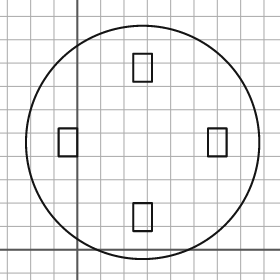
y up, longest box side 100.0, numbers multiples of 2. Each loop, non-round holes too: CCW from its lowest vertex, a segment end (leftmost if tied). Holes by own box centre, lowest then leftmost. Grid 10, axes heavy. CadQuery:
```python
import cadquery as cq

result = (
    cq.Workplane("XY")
    .moveTo(28.0, 46.0)
    .circle(50.0)
    .moveTo(24.0, 8.0)
    .lineTo(32.0, 8.0)
    .lineTo(32.0, 20.0)
    .lineTo(24.0, 20.0)
    .close()
    .moveTo(-8.0, 40.0)
    .lineTo(0.0, 40.0)
    .lineTo(0.0, 52.0)
    .lineTo(-8.0, 52.0)
    .close()
    .moveTo(56.0, 40.0)
    .lineTo(64.0, 40.0)
    .lineTo(64.0, 52.0)
    .lineTo(56.0, 52.0)
    .close()
    .moveTo(24.0, 72.0)
    .lineTo(32.0, 72.0)
    .lineTo(32.0, 84.0)
    .lineTo(24.0, 84.0)
    .close()
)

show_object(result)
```